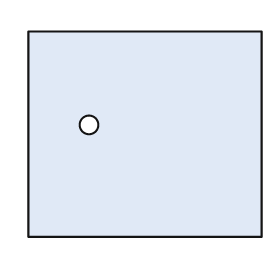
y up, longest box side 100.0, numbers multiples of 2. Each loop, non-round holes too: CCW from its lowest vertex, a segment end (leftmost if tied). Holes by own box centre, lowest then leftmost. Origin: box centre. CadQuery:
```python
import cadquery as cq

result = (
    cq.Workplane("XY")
    .moveTo(-50.0, -44.0)
    .lineTo(50.0, -44.0)
    .lineTo(50.0, 44.0)
    .lineTo(-50.0, 44.0)
    .close()
    .moveTo(-24.0, 4.0)
    .circle(4.0)
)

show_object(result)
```